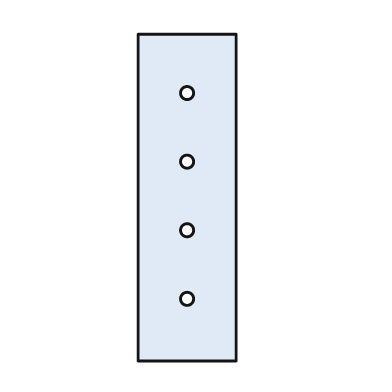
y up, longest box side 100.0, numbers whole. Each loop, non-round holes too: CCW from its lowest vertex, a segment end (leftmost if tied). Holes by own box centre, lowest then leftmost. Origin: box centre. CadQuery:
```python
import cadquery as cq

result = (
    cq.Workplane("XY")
    .moveTo(-15.0, -50.0)
    .lineTo(15.0, -50.0)
    .lineTo(15.0, 50.0)
    .lineTo(-15.0, 50.0)
    .close()
    .moveTo(0.0, -31.0)
    .circle(2.0)
    .moveTo(0.0, -10.0)
    .circle(2.0)
    .moveTo(0.0, 11.0)
    .circle(2.0)
    .moveTo(0.0, 32.0)
    .circle(2.0)
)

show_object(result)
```